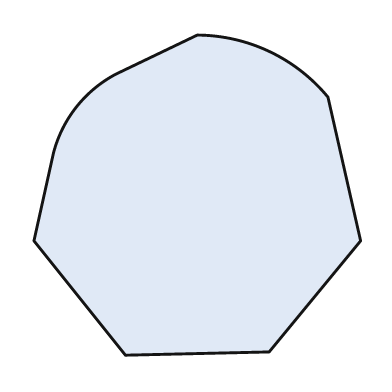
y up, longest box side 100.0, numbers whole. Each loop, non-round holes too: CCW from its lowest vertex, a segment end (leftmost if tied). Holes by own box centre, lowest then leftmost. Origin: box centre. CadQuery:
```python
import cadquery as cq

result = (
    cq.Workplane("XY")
    .moveTo(-22.0, -49.0)
    .lineTo(22.0, -48.0)
    .lineTo(50.0, -14.0)
    .lineTo(40.0, 30.0)
    .threePointArc((22.0, 44.0), (0.0, 49.0))
    .lineTo(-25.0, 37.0)
    .threePointArc((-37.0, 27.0), (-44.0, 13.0))
    .lineTo(-50.0, -14.0)
    .close()
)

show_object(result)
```